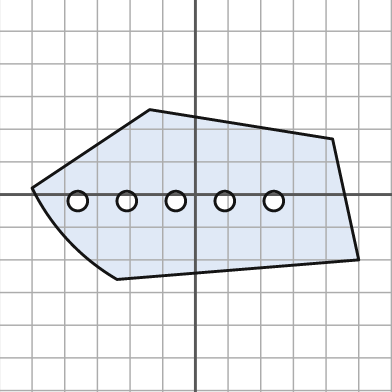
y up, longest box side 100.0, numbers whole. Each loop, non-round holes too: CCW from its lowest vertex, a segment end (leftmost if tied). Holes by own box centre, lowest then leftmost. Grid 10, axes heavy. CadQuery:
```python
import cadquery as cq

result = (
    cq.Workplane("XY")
    .moveTo(-24.0, -26.0)
    .lineTo(50.0, -20.0)
    .lineTo(42.0, 17.0)
    .lineTo(-14.0, 26.0)
    .lineTo(-50.0, 2.0)
    .threePointArc((-39.0, -14.0), (-24.0, -26.0))
    .close()
    .moveTo(-36.0, -2.0)
    .circle(3.0)
    .moveTo(-21.0, -2.0)
    .circle(3.0)
    .moveTo(-6.0, -2.0)
    .circle(3.0)
    .moveTo(9.0, -2.0)
    .circle(3.0)
    .moveTo(24.0, -2.0)
    .circle(3.0)
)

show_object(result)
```